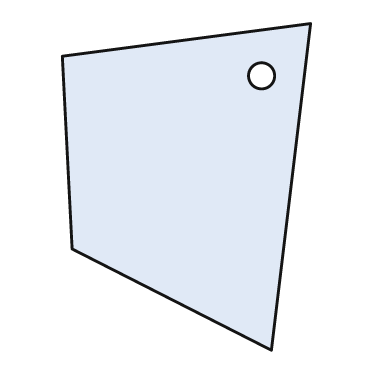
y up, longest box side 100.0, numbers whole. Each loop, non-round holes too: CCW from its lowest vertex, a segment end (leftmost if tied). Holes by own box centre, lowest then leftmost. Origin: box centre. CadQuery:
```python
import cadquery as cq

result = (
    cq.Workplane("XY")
    .moveTo(26.0, -50.0)
    .lineTo(38.0, 50.0)
    .lineTo(-38.0, 40.0)
    .lineTo(-35.0, -19.0)
    .close()
    .moveTo(23.0, 34.0)
    .circle(4.0)
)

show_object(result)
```